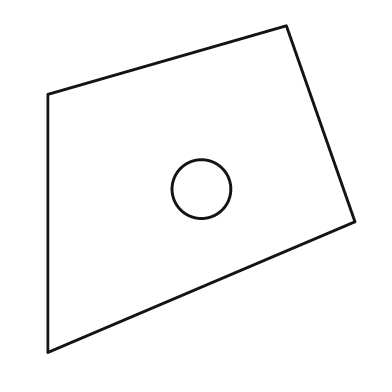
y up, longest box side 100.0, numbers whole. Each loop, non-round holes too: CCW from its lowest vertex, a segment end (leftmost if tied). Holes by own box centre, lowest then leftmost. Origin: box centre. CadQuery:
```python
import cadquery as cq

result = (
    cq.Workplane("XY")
    .moveTo(-47.0, -50.0)
    .lineTo(47.0, -10.0)
    .lineTo(26.0, 50.0)
    .lineTo(-47.0, 29.0)
    .close()
    .moveTo(0.0, 0.0)
    .circle(9.0)
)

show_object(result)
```